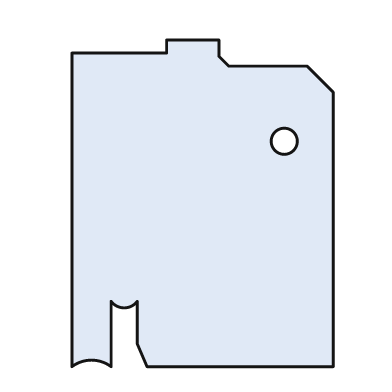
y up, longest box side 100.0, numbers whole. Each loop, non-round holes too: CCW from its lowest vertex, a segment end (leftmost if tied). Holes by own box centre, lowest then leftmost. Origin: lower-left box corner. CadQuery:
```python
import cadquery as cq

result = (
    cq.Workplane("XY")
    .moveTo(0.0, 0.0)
    .threePointArc((6.0, 2.0), (12.0, 0.0))
    .lineTo(12.0, 20.0)
    .threePointArc((16.0, 18.0), (20.0, 20.0))
    .lineTo(20.0, 7.0)
    .lineTo(23.0, 0.0)
    .lineTo(80.0, 0.0)
    .lineTo(80.0, 84.0)
    .lineTo(72.0, 92.0)
    .lineTo(48.0, 92.0)
    .lineTo(45.0, 95.0)
    .lineTo(45.0, 100.0)
    .lineTo(29.0, 100.0)
    .lineTo(29.0, 96.0)
    .lineTo(0.0, 96.0)
    .close()
    .moveTo(65.0, 69.0)
    .circle(4.0)
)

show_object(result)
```